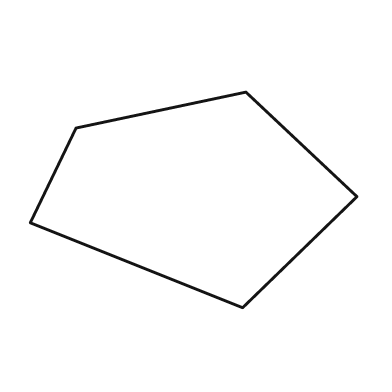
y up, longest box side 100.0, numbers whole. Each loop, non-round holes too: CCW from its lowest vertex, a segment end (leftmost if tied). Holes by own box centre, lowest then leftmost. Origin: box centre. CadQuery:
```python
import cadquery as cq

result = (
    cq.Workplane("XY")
    .moveTo(15.0, -33.0)
    .lineTo(50.0, 1.0)
    .lineTo(16.0, 33.0)
    .lineTo(-36.0, 22.0)
    .lineTo(-50.0, -7.0)
    .close()
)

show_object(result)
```